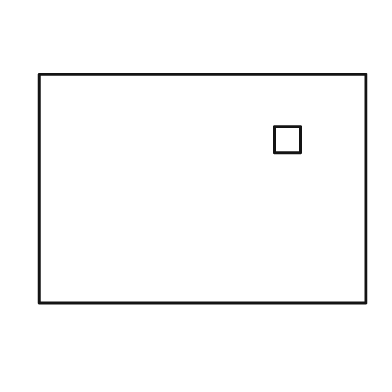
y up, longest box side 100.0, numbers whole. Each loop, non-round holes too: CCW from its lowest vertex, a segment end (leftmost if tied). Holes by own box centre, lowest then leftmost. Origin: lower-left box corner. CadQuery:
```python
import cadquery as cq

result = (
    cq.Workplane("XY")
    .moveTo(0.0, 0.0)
    .lineTo(100.0, 0.0)
    .lineTo(100.0, 70.0)
    .lineTo(0.0, 70.0)
    .close()
    .moveTo(72.0, 46.0)
    .lineTo(80.0, 46.0)
    .lineTo(80.0, 54.0)
    .lineTo(72.0, 54.0)
    .close()
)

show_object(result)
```